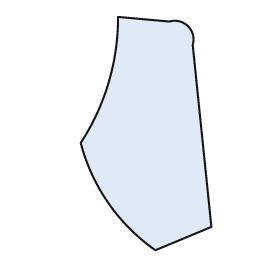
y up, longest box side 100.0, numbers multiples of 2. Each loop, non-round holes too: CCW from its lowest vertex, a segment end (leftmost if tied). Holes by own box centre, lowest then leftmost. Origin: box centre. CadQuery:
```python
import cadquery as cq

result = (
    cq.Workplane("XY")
    .moveTo(4.0, -50.0)
    .lineTo(28.0, -40.0)
    .lineTo(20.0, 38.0)
    .threePointArc((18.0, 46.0), (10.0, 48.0))
    .lineTo(-12.0, 50.0)
    .threePointArc((-16.0, 22.0), (-28.0, -4.0))
    .threePointArc((-16.0, -30.0), (4.0, -50.0))
    .close()
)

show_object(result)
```